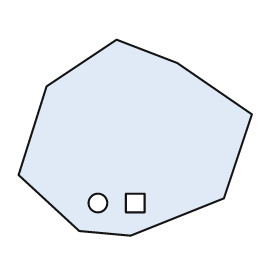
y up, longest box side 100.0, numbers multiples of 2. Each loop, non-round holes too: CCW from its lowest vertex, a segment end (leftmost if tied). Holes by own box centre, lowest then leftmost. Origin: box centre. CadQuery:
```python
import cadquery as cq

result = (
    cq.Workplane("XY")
    .moveTo(-2.0, -42.0)
    .lineTo(38.0, -26.0)
    .lineTo(50.0, 10.0)
    .lineTo(18.0, 32.0)
    .lineTo(-8.0, 42.0)
    .lineTo(-38.0, 22.0)
    .lineTo(-50.0, -16.0)
    .lineTo(-24.0, -40.0)
    .close()
    .moveTo(-16.0, -28.0)
    .circle(4.0)
    .moveTo(-4.0, -32.0)
    .lineTo(4.0, -32.0)
    .lineTo(4.0, -24.0)
    .lineTo(-4.0, -24.0)
    .close()
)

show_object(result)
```